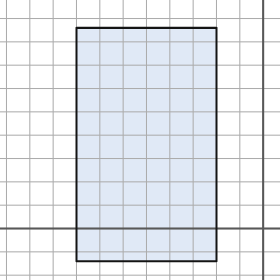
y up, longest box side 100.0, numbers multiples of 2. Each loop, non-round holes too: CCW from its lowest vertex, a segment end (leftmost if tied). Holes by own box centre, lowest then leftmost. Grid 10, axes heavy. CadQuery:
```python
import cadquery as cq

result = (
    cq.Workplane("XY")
    .moveTo(-80.0, -14.0)
    .lineTo(-20.0, -14.0)
    .lineTo(-20.0, 86.0)
    .lineTo(-80.0, 86.0)
    .close()
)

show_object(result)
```